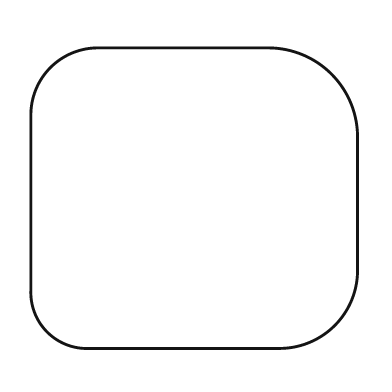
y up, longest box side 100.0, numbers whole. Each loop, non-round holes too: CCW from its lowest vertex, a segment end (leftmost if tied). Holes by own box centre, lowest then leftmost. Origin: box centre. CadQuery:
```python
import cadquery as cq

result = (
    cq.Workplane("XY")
    .moveTo(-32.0, -46.0)
    .lineTo(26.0, -46.0)
    .threePointArc((43.0, -39.0), (50.0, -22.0))
    .lineTo(50.0, 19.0)
    .threePointArc((42.0, 38.0), (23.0, 46.0))
    .lineTo(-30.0, 46.0)
    .threePointArc((-44.0, 40.0), (-50.0, 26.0))
    .lineTo(-50.0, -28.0)
    .threePointArc((-45.0, -41.0), (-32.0, -46.0))
    .close()
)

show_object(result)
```